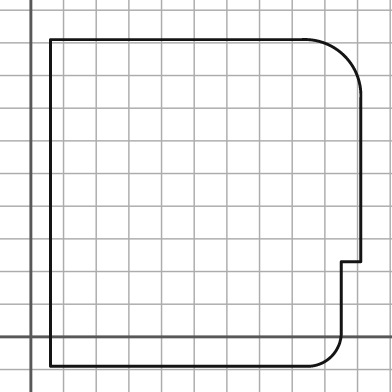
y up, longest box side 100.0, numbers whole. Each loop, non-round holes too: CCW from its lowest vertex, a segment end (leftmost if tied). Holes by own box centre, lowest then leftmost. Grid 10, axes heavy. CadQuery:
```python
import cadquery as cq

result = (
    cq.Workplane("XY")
    .moveTo(6.0, -9.0)
    .lineTo(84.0, -9.0)
    .threePointArc((92.0, -6.0), (95.0, 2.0))
    .lineTo(95.0, 23.0)
    .lineTo(101.0, 23.0)
    .lineTo(101.0, 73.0)
    .threePointArc((96.0, 86.0), (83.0, 91.0))
    .lineTo(6.0, 91.0)
    .close()
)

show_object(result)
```